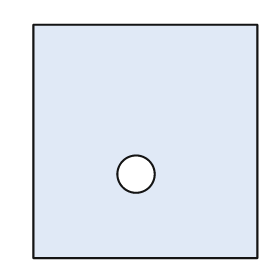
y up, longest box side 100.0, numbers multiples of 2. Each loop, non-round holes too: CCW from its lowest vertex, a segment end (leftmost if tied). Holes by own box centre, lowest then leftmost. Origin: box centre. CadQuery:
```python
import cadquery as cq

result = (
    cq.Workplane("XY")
    .moveTo(-48.0, -50.0)
    .lineTo(48.0, -50.0)
    .lineTo(48.0, 50.0)
    .lineTo(-48.0, 50.0)
    .close()
    .moveTo(-4.0, -14.0)
    .circle(8.0)
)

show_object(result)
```